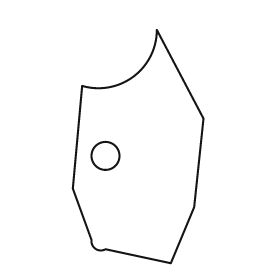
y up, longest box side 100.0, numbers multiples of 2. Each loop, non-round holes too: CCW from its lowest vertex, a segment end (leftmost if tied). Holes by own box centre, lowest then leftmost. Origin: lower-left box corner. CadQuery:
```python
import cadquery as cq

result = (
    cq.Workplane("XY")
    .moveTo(42.0, 0.0)
    .lineTo(52.0, 24.0)
    .lineTo(56.0, 62.0)
    .lineTo(36.0, 100.0)
    .threePointArc((26.0, 80.0), (4.0, 76.0))
    .lineTo(0.0, 32.0)
    .lineTo(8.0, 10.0)
    .threePointArc((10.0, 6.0), (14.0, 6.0))
    .close()
    .moveTo(14.0, 46.0)
    .circle(6.0)
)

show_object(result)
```